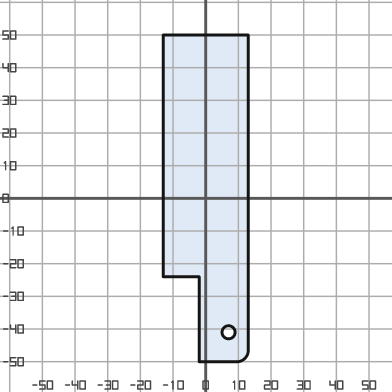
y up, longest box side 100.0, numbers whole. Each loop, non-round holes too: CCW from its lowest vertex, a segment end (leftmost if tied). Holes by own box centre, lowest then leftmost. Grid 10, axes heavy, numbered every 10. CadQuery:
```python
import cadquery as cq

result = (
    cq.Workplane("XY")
    .moveTo(-2.0, -50.0)
    .lineTo(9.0, -50.0)
    .threePointArc((12.0, -49.0), (13.0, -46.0))
    .lineTo(13.0, 50.0)
    .lineTo(-13.0, 50.0)
    .lineTo(-13.0, -24.0)
    .lineTo(-2.0, -24.0)
    .close()
    .moveTo(7.0, -41.0)
    .circle(2.0)
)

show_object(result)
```